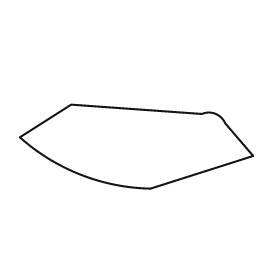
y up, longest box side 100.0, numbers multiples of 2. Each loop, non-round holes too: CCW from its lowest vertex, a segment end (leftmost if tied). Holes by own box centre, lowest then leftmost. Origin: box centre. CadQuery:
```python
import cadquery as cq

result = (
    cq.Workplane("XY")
    .moveTo(6.0, -18.0)
    .lineTo(50.0, -4.0)
    .lineTo(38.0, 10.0)
    .threePointArc((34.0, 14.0), (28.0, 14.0))
    .lineTo(-28.0, 18.0)
    .lineTo(-50.0, 4.0)
    .threePointArc((-24.0, -12.0), (6.0, -18.0))
    .close()
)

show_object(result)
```